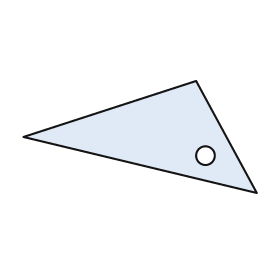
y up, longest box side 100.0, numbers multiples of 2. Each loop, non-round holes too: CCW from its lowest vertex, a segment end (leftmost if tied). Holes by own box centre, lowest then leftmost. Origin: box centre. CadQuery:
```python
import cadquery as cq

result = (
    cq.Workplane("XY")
    .moveTo(50.0, -24.0)
    .lineTo(24.0, 24.0)
    .lineTo(-50.0, 0.0)
    .close()
    .moveTo(28.0, -8.0)
    .circle(4.0)
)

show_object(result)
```